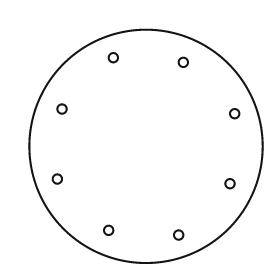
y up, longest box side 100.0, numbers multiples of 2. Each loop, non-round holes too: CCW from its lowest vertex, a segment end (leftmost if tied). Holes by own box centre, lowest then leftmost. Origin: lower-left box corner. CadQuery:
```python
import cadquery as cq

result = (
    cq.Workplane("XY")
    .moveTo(50.0, 50.0)
    .circle(50.0)
    .moveTo(64.0, 12.0)
    .circle(2.0)
    .moveTo(34.0, 14.0)
    .circle(2.0)
    .moveTo(86.0, 34.0)
    .circle(2.0)
    .moveTo(12.0, 36.0)
    .circle(2.0)
    .moveTo(88.0, 64.0)
    .circle(2.0)
    .moveTo(14.0, 66.0)
    .circle(2.0)
    .moveTo(66.0, 86.0)
    .circle(2.0)
    .moveTo(36.0, 88.0)
    .circle(2.0)
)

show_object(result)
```